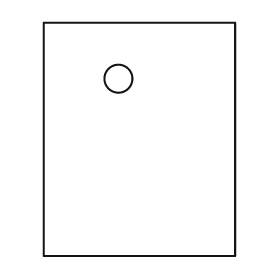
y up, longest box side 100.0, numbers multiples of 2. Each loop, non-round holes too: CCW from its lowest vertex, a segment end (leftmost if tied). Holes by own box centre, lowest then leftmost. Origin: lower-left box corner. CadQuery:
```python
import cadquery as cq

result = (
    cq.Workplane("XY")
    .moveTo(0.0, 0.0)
    .lineTo(82.0, 0.0)
    .lineTo(82.0, 100.0)
    .lineTo(0.0, 100.0)
    .close()
    .moveTo(32.0, 76.0)
    .circle(6.0)
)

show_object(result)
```